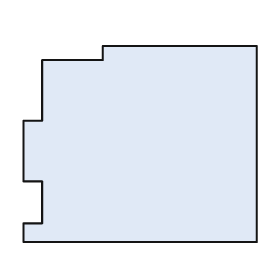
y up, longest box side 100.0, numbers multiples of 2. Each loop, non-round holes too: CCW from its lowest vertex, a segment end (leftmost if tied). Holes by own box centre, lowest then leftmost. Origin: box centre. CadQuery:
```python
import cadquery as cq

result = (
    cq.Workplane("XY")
    .moveTo(-50.0, -42.0)
    .lineTo(50.0, -42.0)
    .lineTo(50.0, 42.0)
    .lineTo(-16.0, 42.0)
    .lineTo(-16.0, 36.0)
    .lineTo(-42.0, 36.0)
    .lineTo(-42.0, 10.0)
    .lineTo(-50.0, 10.0)
    .lineTo(-50.0, -16.0)
    .lineTo(-42.0, -16.0)
    .lineTo(-42.0, -34.0)
    .lineTo(-50.0, -34.0)
    .close()
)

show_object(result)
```